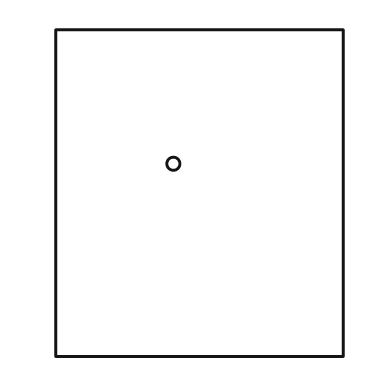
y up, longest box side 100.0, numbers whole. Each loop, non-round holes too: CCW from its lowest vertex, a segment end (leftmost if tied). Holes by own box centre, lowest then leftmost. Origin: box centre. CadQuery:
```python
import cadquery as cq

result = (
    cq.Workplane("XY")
    .moveTo(-44.0, -50.0)
    .lineTo(44.0, -50.0)
    .lineTo(44.0, 50.0)
    .lineTo(-44.0, 50.0)
    .close()
    .moveTo(-8.0, 9.0)
    .circle(2.0)
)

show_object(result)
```